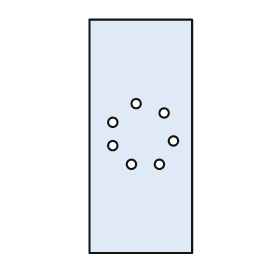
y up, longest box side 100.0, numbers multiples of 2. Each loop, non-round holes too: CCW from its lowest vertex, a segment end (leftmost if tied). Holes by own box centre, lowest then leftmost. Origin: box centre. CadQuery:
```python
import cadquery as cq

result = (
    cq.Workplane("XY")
    .moveTo(-22.0, -50.0)
    .lineTo(22.0, -50.0)
    .lineTo(22.0, 50.0)
    .lineTo(-22.0, 50.0)
    .close()
    .moveTo(-4.0, -12.0)
    .circle(2.0)
    .moveTo(8.0, -12.0)
    .circle(2.0)
    .moveTo(-12.0, -4.0)
    .circle(2.0)
    .moveTo(14.0, -2.0)
    .circle(2.0)
    .moveTo(-12.0, 6.0)
    .circle(2.0)
    .moveTo(10.0, 10.0)
    .circle(2.0)
    .moveTo(-2.0, 14.0)
    .circle(2.0)
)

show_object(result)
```